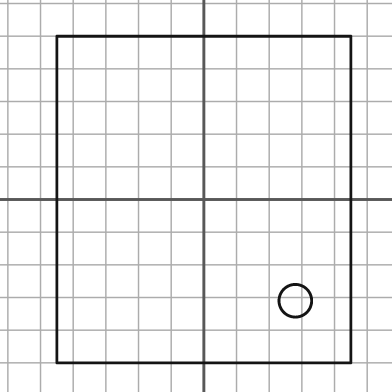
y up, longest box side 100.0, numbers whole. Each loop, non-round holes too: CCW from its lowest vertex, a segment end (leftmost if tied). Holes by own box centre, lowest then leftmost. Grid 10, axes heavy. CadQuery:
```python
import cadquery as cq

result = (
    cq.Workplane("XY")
    .moveTo(-45.0, -50.0)
    .lineTo(45.0, -50.0)
    .lineTo(45.0, 50.0)
    .lineTo(-45.0, 50.0)
    .close()
    .moveTo(28.0, -31.0)
    .circle(5.0)
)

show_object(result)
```